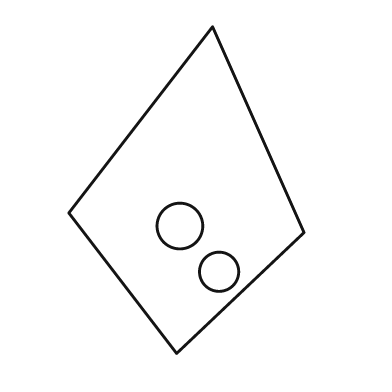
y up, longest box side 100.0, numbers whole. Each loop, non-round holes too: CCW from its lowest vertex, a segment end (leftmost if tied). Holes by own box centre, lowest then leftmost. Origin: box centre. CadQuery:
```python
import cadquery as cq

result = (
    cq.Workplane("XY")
    .moveTo(-3.0, -50.0)
    .lineTo(36.0, -13.0)
    .lineTo(8.0, 50.0)
    .lineTo(-36.0, -7.0)
    .close()
    .moveTo(10.0, -25.0)
    .circle(6.0)
    .moveTo(-2.0, -11.0)
    .circle(7.0)
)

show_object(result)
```